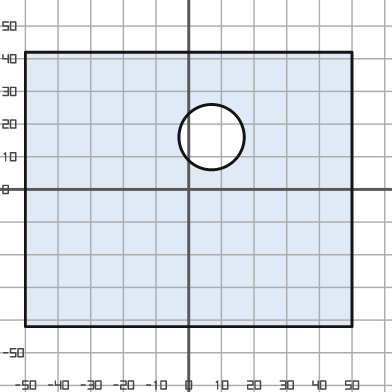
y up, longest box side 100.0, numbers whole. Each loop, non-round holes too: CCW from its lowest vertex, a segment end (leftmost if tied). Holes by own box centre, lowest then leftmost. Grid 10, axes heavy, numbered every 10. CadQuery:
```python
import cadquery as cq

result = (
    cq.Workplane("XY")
    .moveTo(-50.0, -42.0)
    .lineTo(50.0, -42.0)
    .lineTo(50.0, 42.0)
    .lineTo(-50.0, 42.0)
    .close()
    .moveTo(7.0, 16.0)
    .circle(10.0)
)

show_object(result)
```